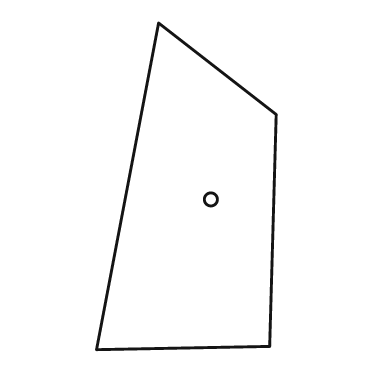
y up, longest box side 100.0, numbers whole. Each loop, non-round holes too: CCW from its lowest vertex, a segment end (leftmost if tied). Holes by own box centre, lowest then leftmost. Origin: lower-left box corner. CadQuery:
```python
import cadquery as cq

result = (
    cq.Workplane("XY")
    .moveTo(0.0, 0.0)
    .lineTo(53.0, 1.0)
    .lineTo(55.0, 72.0)
    .lineTo(19.0, 100.0)
    .close()
    .moveTo(35.0, 46.0)
    .circle(2.0)
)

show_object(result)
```